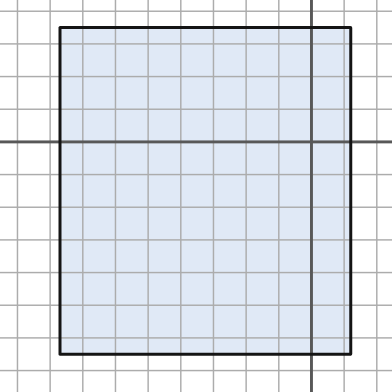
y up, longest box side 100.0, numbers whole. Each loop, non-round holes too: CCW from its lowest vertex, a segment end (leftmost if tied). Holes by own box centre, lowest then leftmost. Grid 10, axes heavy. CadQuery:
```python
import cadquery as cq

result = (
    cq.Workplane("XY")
    .moveTo(-77.0, -65.0)
    .lineTo(12.0, -65.0)
    .lineTo(12.0, 35.0)
    .lineTo(-77.0, 35.0)
    .close()
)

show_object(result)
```